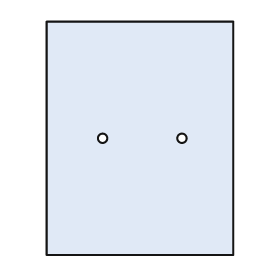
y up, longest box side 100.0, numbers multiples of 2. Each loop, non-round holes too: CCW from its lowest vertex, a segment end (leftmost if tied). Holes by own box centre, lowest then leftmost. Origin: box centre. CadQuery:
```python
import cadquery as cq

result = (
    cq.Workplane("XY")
    .moveTo(-40.0, -50.0)
    .lineTo(40.0, -50.0)
    .lineTo(40.0, 50.0)
    .lineTo(-40.0, 50.0)
    .close()
    .moveTo(-16.0, 0.0)
    .circle(2.0)
    .moveTo(18.0, 0.0)
    .circle(2.0)
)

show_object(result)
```